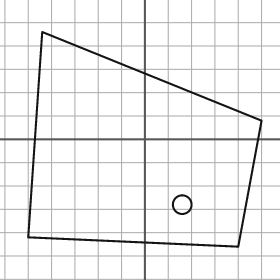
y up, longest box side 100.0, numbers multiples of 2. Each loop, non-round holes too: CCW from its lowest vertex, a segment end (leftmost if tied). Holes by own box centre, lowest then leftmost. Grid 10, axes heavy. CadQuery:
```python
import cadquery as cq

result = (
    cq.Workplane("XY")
    .moveTo(40.0, -46.0)
    .lineTo(50.0, 8.0)
    .lineTo(-44.0, 46.0)
    .lineTo(-50.0, -42.0)
    .close()
    .moveTo(16.0, -28.0)
    .circle(4.0)
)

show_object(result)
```